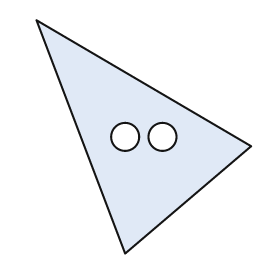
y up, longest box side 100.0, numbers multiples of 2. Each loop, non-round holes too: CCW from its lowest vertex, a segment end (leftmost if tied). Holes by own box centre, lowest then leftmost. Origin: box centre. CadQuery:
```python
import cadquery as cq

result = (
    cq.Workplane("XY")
    .moveTo(-8.0, -50.0)
    .lineTo(46.0, -4.0)
    .lineTo(-46.0, 50.0)
    .close()
    .moveTo(-8.0, 0.0)
    .circle(6.0)
    .moveTo(8.0, 0.0)
    .circle(6.0)
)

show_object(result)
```